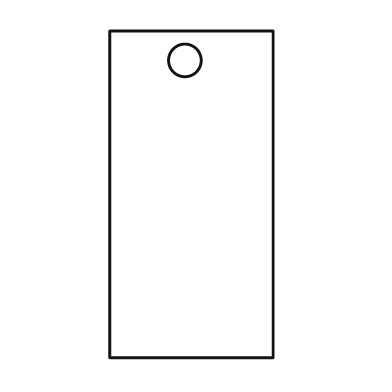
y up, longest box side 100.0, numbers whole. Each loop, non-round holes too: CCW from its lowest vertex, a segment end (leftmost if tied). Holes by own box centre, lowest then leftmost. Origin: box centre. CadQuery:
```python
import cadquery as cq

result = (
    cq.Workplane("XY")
    .moveTo(-25.0, -50.0)
    .lineTo(25.0, -50.0)
    .lineTo(25.0, 50.0)
    .lineTo(-25.0, 50.0)
    .close()
    .moveTo(-2.0, 41.0)
    .circle(5.0)
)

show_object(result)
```